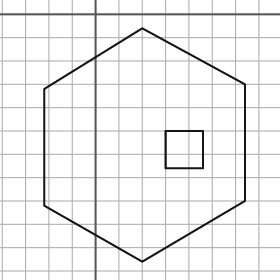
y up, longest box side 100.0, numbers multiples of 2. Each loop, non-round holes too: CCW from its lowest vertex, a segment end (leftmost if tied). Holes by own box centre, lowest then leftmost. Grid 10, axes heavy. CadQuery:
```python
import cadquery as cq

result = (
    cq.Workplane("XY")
    .moveTo(20.0, -106.0)
    .lineTo(64.0, -80.0)
    .lineTo(64.0, -30.0)
    .lineTo(20.0, -6.0)
    .lineTo(-22.0, -32.0)
    .lineTo(-22.0, -82.0)
    .close()
    .moveTo(30.0, -66.0)
    .lineTo(46.0, -66.0)
    .lineTo(46.0, -50.0)
    .lineTo(30.0, -50.0)
    .close()
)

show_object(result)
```